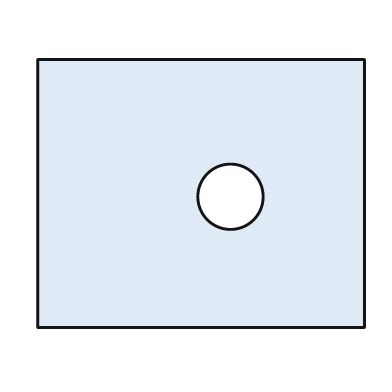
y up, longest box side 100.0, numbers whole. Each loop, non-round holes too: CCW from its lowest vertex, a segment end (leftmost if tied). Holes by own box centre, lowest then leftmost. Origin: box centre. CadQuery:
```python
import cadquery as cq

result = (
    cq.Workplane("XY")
    .moveTo(-50.0, -41.0)
    .lineTo(50.0, -41.0)
    .lineTo(50.0, 41.0)
    .lineTo(-50.0, 41.0)
    .close()
    .moveTo(9.0, -1.0)
    .circle(10.0)
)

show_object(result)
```